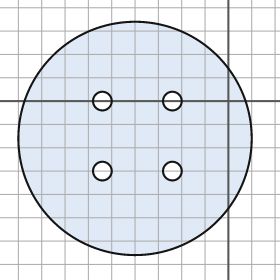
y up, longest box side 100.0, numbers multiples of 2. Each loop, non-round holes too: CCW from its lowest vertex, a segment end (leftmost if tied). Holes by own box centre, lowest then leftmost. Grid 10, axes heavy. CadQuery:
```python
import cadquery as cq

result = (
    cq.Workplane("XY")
    .moveTo(-40.0, -16.0)
    .circle(50.0)
    .moveTo(-54.0, -30.0)
    .circle(4.0)
    .moveTo(-24.0, -30.0)
    .circle(4.0)
    .moveTo(-54.0, 0.0)
    .circle(4.0)
    .moveTo(-24.0, 0.0)
    .circle(4.0)
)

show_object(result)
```